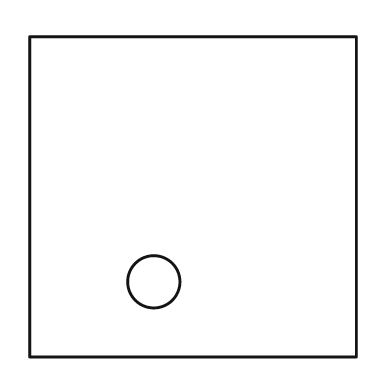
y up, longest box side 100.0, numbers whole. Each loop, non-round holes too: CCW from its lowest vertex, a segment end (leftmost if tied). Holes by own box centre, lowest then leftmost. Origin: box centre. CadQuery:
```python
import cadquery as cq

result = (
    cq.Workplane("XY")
    .moveTo(-50.0, -49.0)
    .lineTo(50.0, -49.0)
    .lineTo(50.0, 49.0)
    .lineTo(-50.0, 49.0)
    .close()
    .moveTo(-12.0, -26.0)
    .circle(8.0)
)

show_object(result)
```